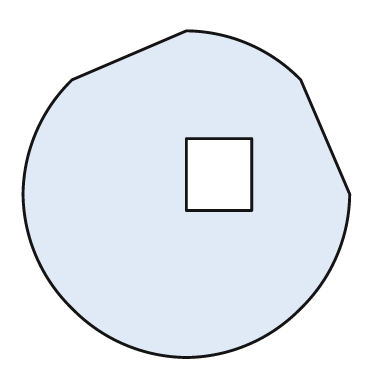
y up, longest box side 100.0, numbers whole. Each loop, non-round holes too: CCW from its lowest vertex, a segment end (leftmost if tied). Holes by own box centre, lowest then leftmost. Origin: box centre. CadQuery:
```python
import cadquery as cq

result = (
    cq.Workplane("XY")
    .moveTo(0.0, -50.0)
    .threePointArc((19.0, -46.0), (35.0, -35.0))
    .threePointArc((46.0, -19.0), (50.0, 0.0))
    .lineTo(35.0, 35.0)
    .threePointArc((19.0, 46.0), (0.0, 50.0))
    .lineTo(-35.0, 35.0)
    .threePointArc((-46.0, 19.0), (-50.0, 0.0))
    .threePointArc((-46.0, -19.0), (-35.0, -35.0))
    .threePointArc((-19.0, -46.0), (0.0, -50.0))
    .close()
    .moveTo(0.0, -5.0)
    .lineTo(20.0, -5.0)
    .lineTo(20.0, 17.0)
    .lineTo(0.0, 17.0)
    .close()
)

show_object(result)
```